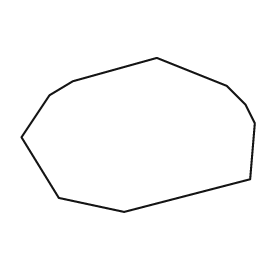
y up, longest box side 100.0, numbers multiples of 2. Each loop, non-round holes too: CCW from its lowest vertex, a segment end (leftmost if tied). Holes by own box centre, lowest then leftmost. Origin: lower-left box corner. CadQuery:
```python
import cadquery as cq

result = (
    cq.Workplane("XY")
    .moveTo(44.0, 0.0)
    .lineTo(98.0, 14.0)
    .lineTo(100.0, 38.0)
    .lineTo(96.0, 46.0)
    .lineTo(88.0, 54.0)
    .lineTo(58.0, 66.0)
    .lineTo(22.0, 56.0)
    .lineTo(12.0, 50.0)
    .lineTo(0.0, 32.0)
    .lineTo(16.0, 6.0)
    .close()
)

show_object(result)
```